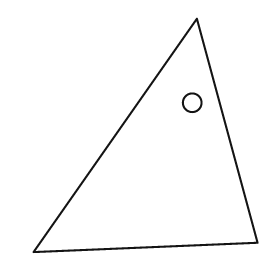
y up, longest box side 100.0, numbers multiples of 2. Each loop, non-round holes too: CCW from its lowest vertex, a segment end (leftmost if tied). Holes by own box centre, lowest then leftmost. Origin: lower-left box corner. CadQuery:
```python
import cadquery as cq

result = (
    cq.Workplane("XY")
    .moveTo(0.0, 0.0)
    .lineTo(96.0, 4.0)
    .lineTo(70.0, 100.0)
    .close()
    .moveTo(68.0, 64.0)
    .circle(4.0)
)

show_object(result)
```